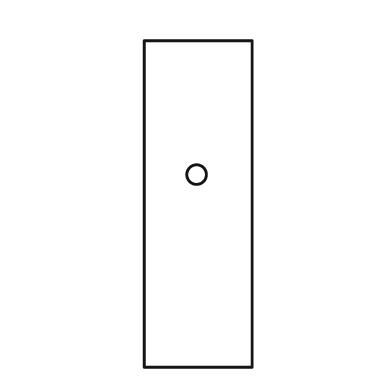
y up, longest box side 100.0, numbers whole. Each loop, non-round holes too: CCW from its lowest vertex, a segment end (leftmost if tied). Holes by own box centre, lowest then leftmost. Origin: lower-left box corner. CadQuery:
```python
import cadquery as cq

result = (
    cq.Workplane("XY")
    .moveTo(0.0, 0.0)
    .lineTo(33.0, 0.0)
    .lineTo(33.0, 100.0)
    .lineTo(0.0, 100.0)
    .close()
    .moveTo(16.0, 59.0)
    .circle(3.0)
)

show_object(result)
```